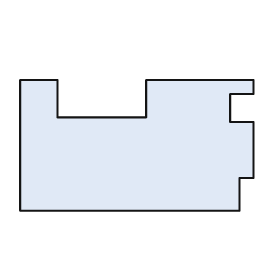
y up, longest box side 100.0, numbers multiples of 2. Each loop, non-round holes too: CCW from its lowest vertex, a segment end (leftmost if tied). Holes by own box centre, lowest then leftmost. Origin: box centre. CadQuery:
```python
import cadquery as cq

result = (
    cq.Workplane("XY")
    .moveTo(-50.0, -28.0)
    .lineTo(44.0, -28.0)
    .lineTo(44.0, -14.0)
    .lineTo(50.0, -14.0)
    .lineTo(50.0, 10.0)
    .lineTo(40.0, 10.0)
    .lineTo(40.0, 22.0)
    .lineTo(50.0, 22.0)
    .lineTo(50.0, 28.0)
    .lineTo(4.0, 28.0)
    .lineTo(4.0, 12.0)
    .lineTo(-34.0, 12.0)
    .lineTo(-34.0, 28.0)
    .lineTo(-50.0, 28.0)
    .close()
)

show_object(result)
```